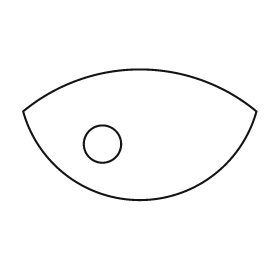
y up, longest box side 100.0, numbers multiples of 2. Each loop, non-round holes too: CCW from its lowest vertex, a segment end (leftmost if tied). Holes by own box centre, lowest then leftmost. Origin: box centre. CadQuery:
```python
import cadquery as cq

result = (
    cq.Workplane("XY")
    .moveTo(-50.0, 10.0)
    .threePointArc((0.0, -28.0), (50.0, 10.0))
    .threePointArc((0.0, 28.0), (-50.0, 10.0))
    .close()
    .moveTo(-16.0, -4.0)
    .circle(8.0)
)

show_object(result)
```